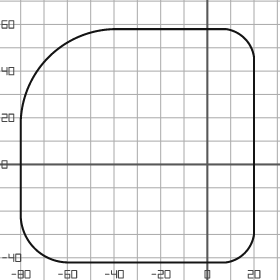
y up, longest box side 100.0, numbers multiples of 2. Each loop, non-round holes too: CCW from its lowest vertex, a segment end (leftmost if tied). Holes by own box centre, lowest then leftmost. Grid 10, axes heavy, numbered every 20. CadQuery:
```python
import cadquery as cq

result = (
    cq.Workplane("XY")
    .moveTo(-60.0, -42.0)
    .lineTo(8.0, -42.0)
    .threePointArc((16.0, -38.0), (20.0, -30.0))
    .lineTo(20.0, 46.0)
    .threePointArc((16.0, 54.0), (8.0, 58.0))
    .lineTo(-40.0, 58.0)
    .threePointArc((-68.0, 46.0), (-80.0, 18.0))
    .lineTo(-80.0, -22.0)
    .threePointArc((-74.0, -36.0), (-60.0, -42.0))
    .close()
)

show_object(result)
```